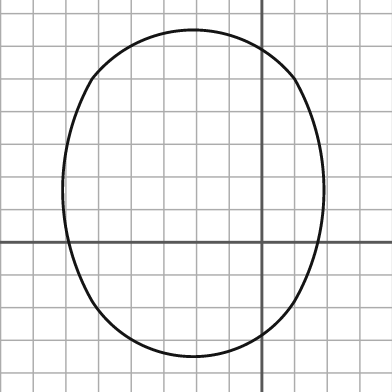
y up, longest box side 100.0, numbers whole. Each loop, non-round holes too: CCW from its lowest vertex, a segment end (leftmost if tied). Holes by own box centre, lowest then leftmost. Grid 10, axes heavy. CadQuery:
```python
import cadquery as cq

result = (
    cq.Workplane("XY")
    .moveTo(-52.0, -18.0)
    .threePointArc((-21.0, -35.0), (10.0, -18.0))
    .threePointArc((19.0, 16.0), (10.0, 50.0))
    .threePointArc((-21.0, 65.0), (-52.0, 50.0))
    .threePointArc((-61.0, 16.0), (-52.0, -18.0))
    .close()
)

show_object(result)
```